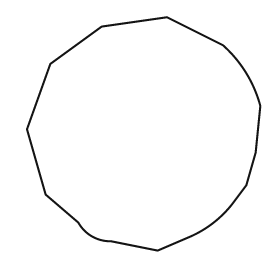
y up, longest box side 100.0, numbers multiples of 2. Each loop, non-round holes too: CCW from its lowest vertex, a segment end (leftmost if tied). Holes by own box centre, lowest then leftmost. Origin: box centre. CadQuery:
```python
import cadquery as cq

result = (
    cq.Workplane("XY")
    .moveTo(6.0, -50.0)
    .lineTo(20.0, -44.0)
    .threePointArc((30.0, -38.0), (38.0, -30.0))
    .lineTo(44.0, -22.0)
    .lineTo(48.0, -8.0)
    .lineTo(50.0, 12.0)
    .threePointArc((44.0, 26.0), (34.0, 38.0))
    .lineTo(10.0, 50.0)
    .lineTo(-18.0, 46.0)
    .lineTo(-40.0, 30.0)
    .lineTo(-50.0, 2.0)
    .lineTo(-42.0, -26.0)
    .lineTo(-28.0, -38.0)
    .threePointArc((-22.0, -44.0), (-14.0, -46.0))
    .close()
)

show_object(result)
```